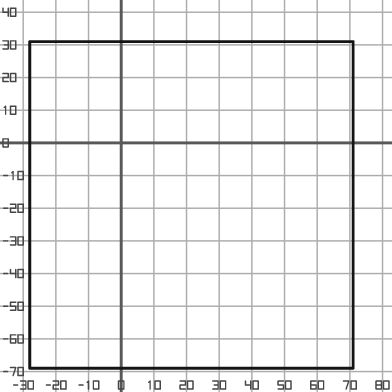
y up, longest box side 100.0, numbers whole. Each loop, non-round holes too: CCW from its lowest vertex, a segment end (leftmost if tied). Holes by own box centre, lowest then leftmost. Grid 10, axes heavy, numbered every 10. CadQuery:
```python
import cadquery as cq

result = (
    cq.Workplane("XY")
    .moveTo(-28.0, -69.0)
    .lineTo(71.0, -69.0)
    .lineTo(71.0, 31.0)
    .lineTo(-28.0, 31.0)
    .close()
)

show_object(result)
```